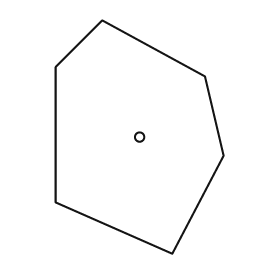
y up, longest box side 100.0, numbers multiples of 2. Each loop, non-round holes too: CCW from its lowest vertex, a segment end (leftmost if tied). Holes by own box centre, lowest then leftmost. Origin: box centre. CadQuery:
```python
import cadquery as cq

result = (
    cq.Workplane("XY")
    .moveTo(14.0, -50.0)
    .lineTo(36.0, -8.0)
    .lineTo(28.0, 26.0)
    .lineTo(-16.0, 50.0)
    .lineTo(-36.0, 30.0)
    .lineTo(-36.0, -28.0)
    .close()
    .moveTo(0.0, 0.0)
    .circle(2.0)
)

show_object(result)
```